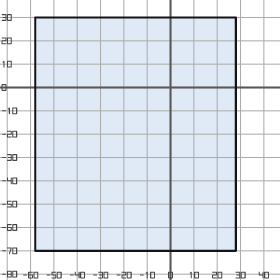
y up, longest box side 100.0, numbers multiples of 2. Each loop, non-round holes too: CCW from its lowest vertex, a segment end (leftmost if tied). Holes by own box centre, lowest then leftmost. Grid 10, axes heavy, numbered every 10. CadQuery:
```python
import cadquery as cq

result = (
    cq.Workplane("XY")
    .moveTo(-58.0, -70.0)
    .lineTo(28.0, -70.0)
    .lineTo(28.0, 30.0)
    .lineTo(-58.0, 30.0)
    .close()
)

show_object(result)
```